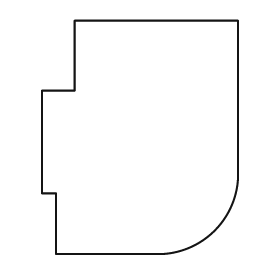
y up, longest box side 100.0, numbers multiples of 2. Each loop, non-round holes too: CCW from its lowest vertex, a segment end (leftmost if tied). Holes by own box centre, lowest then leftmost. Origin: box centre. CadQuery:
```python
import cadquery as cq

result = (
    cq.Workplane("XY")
    .moveTo(-36.0, -50.0)
    .lineTo(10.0, -50.0)
    .threePointArc((32.0, -40.0), (42.0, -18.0))
    .lineTo(42.0, 50.0)
    .lineTo(-28.0, 50.0)
    .lineTo(-28.0, 20.0)
    .lineTo(-42.0, 20.0)
    .lineTo(-42.0, -24.0)
    .lineTo(-36.0, -24.0)
    .close()
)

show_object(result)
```